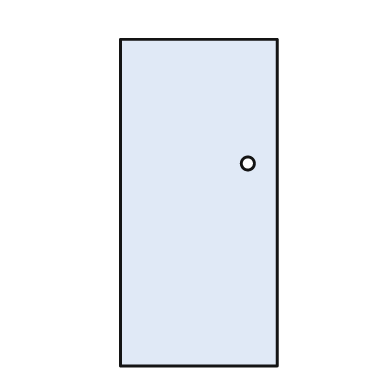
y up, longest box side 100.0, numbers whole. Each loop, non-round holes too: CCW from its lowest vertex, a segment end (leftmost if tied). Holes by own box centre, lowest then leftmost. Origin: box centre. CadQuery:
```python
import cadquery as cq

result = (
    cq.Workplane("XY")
    .moveTo(-24.0, -50.0)
    .lineTo(24.0, -50.0)
    .lineTo(24.0, 50.0)
    .lineTo(-24.0, 50.0)
    .close()
    .moveTo(15.0, 12.0)
    .circle(2.0)
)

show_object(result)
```